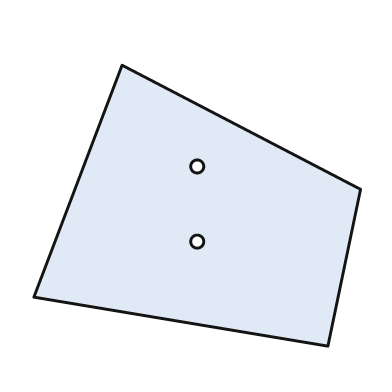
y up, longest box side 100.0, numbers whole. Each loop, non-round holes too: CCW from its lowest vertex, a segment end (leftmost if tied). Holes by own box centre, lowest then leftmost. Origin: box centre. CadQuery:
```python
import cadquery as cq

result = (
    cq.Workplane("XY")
    .moveTo(40.0, -43.0)
    .lineTo(50.0, 5.0)
    .lineTo(-23.0, 43.0)
    .lineTo(-50.0, -28.0)
    .close()
    .moveTo(0.0, -11.0)
    .circle(2.0)
    .moveTo(0.0, 12.0)
    .circle(2.0)
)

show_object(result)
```